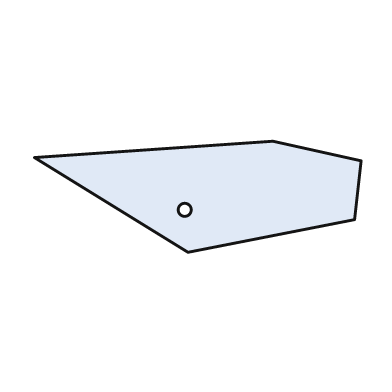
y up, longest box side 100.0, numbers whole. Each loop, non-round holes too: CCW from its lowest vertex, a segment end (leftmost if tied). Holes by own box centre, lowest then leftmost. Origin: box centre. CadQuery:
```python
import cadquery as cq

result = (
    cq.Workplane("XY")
    .moveTo(-3.0, -17.0)
    .lineTo(48.0, -7.0)
    .lineTo(50.0, 11.0)
    .lineTo(23.0, 17.0)
    .lineTo(-50.0, 12.0)
    .close()
    .moveTo(-4.0, -4.0)
    .circle(2.0)
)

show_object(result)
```